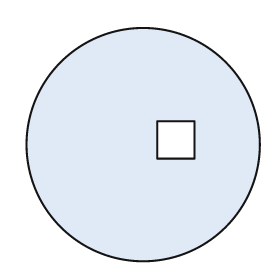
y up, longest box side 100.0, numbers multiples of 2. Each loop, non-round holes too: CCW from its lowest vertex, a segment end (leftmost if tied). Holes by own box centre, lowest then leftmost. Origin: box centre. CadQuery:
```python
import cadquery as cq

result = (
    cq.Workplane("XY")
    .moveTo(0.0, 0.0)
    .circle(50.0)
    .moveTo(6.0, -6.0)
    .lineTo(22.0, -6.0)
    .lineTo(22.0, 10.0)
    .lineTo(6.0, 10.0)
    .close()
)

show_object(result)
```